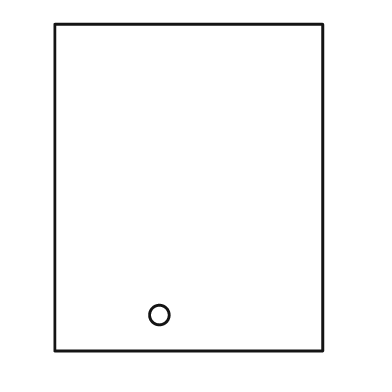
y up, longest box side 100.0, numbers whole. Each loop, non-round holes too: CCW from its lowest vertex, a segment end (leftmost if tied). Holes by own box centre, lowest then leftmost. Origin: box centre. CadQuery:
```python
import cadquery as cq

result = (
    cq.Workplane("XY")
    .moveTo(-41.0, -50.0)
    .lineTo(41.0, -50.0)
    .lineTo(41.0, 50.0)
    .lineTo(-41.0, 50.0)
    .close()
    .moveTo(-9.0, -39.0)
    .circle(3.0)
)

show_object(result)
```